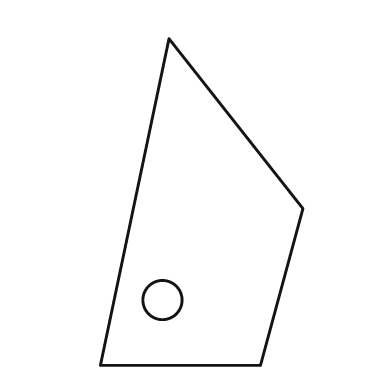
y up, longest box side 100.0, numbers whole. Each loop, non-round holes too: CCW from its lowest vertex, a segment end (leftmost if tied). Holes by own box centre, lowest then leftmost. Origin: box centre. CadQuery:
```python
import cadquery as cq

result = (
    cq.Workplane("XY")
    .moveTo(-31.0, -50.0)
    .lineTo(18.0, -50.0)
    .lineTo(31.0, -2.0)
    .lineTo(-10.0, 50.0)
    .close()
    .moveTo(-12.0, -30.0)
    .circle(6.0)
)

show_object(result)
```